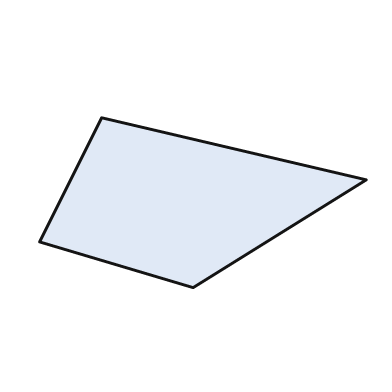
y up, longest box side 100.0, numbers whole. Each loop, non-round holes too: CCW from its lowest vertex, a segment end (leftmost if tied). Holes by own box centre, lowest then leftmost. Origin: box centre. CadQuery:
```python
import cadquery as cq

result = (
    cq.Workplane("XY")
    .moveTo(-3.0, -26.0)
    .lineTo(50.0, 7.0)
    .lineTo(-31.0, 26.0)
    .lineTo(-50.0, -12.0)
    .close()
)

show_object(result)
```